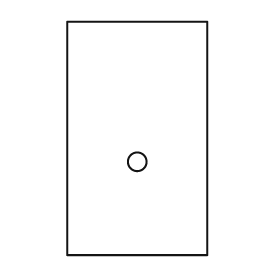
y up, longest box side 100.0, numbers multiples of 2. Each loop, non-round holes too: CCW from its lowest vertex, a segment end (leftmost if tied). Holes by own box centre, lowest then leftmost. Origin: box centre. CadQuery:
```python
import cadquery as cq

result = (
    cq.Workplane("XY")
    .moveTo(-30.0, -50.0)
    .lineTo(30.0, -50.0)
    .lineTo(30.0, 50.0)
    .lineTo(-30.0, 50.0)
    .close()
    .moveTo(0.0, -10.0)
    .circle(4.0)
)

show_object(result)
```